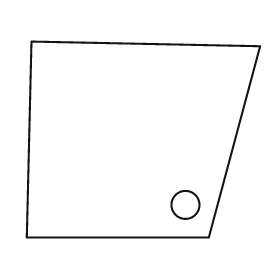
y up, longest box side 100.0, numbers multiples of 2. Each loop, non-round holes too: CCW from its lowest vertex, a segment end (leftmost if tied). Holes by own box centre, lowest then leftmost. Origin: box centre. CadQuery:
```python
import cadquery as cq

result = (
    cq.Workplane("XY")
    .moveTo(-50.0, -42.0)
    .lineTo(28.0, -42.0)
    .lineTo(50.0, 40.0)
    .lineTo(-48.0, 42.0)
    .close()
    .moveTo(18.0, -28.0)
    .circle(6.0)
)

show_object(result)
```